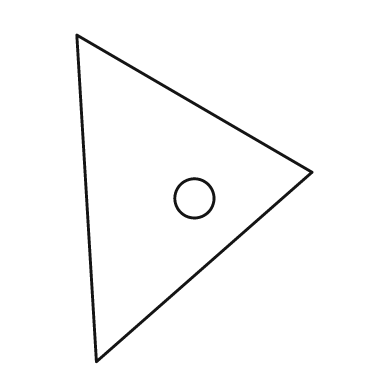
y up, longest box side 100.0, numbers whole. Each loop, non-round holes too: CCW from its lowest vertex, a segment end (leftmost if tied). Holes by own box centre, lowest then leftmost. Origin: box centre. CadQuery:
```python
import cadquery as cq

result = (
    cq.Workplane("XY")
    .moveTo(-30.0, -50.0)
    .lineTo(36.0, 8.0)
    .lineTo(-36.0, 50.0)
    .close()
    .moveTo(0.0, 0.0)
    .circle(6.0)
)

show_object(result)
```